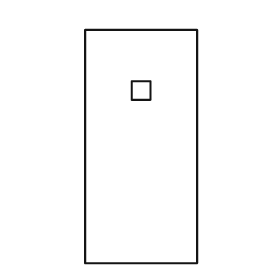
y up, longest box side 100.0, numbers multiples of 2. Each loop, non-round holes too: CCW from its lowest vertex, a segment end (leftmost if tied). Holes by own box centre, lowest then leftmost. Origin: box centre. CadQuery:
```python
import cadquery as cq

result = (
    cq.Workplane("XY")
    .moveTo(-24.0, -50.0)
    .lineTo(24.0, -50.0)
    .lineTo(24.0, 50.0)
    .lineTo(-24.0, 50.0)
    .close()
    .moveTo(-4.0, 20.0)
    .lineTo(4.0, 20.0)
    .lineTo(4.0, 28.0)
    .lineTo(-4.0, 28.0)
    .close()
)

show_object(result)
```